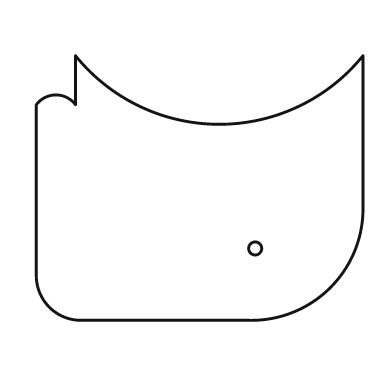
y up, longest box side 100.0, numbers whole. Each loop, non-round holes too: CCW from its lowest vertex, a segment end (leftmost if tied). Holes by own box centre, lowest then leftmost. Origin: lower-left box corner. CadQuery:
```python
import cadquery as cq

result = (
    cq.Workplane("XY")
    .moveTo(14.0, 0.0)
    .lineTo(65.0, 0.0)
    .threePointArc((90.0, 10.0), (100.0, 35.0))
    .lineTo(100.0, 81.0)
    .threePointArc((56.0, 60.0), (12.0, 81.0))
    .lineTo(12.0, 66.0)
    .threePointArc((6.0, 69.0), (0.0, 66.0))
    .lineTo(0.0, 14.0)
    .threePointArc((4.0, 4.0), (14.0, 0.0))
    .close()
    .moveTo(67.0, 22.0)
    .circle(2.0)
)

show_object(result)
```